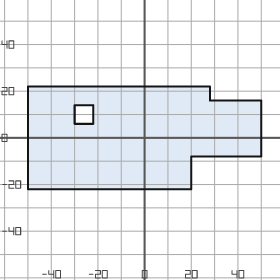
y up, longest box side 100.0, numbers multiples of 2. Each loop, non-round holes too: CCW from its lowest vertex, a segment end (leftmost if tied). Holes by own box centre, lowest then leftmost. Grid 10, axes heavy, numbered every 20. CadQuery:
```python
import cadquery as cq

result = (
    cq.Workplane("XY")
    .moveTo(-50.0, -22.0)
    .lineTo(20.0, -22.0)
    .lineTo(20.0, -8.0)
    .lineTo(50.0, -8.0)
    .lineTo(50.0, 16.0)
    .lineTo(28.0, 16.0)
    .lineTo(28.0, 22.0)
    .lineTo(-50.0, 22.0)
    .close()
    .moveTo(-30.0, 6.0)
    .lineTo(-22.0, 6.0)
    .lineTo(-22.0, 14.0)
    .lineTo(-30.0, 14.0)
    .close()
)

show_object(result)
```